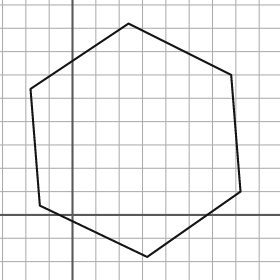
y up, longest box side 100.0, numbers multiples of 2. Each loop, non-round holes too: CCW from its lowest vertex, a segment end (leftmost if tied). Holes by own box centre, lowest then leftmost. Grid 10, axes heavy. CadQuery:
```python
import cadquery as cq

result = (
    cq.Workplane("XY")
    .moveTo(32.0, -18.0)
    .lineTo(72.0, 10.0)
    .lineTo(68.0, 60.0)
    .lineTo(24.0, 82.0)
    .lineTo(-18.0, 54.0)
    .lineTo(-14.0, 4.0)
    .close()
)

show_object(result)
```